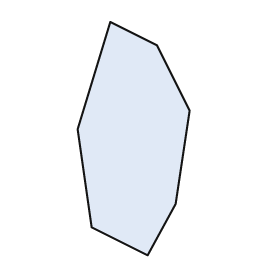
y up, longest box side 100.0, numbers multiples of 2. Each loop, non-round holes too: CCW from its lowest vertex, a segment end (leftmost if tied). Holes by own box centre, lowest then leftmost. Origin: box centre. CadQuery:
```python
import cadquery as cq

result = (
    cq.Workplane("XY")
    .moveTo(6.0, -50.0)
    .lineTo(18.0, -28.0)
    .lineTo(24.0, 12.0)
    .lineTo(10.0, 40.0)
    .lineTo(-10.0, 50.0)
    .lineTo(-24.0, 4.0)
    .lineTo(-18.0, -38.0)
    .close()
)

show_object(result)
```